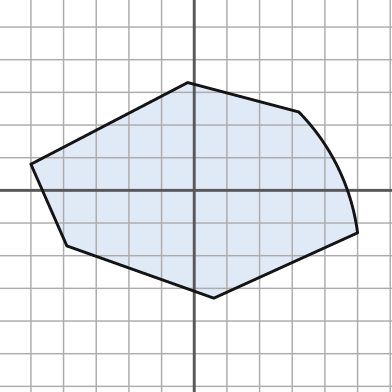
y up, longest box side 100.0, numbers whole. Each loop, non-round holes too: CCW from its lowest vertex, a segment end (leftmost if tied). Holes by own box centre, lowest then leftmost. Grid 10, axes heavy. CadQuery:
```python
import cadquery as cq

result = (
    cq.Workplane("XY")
    .moveTo(6.0, -33.0)
    .lineTo(50.0, -13.0)
    .threePointArc((44.0, 7.0), (32.0, 24.0))
    .lineTo(-2.0, 33.0)
    .lineTo(-50.0, 8.0)
    .lineTo(-39.0, -17.0)
    .close()
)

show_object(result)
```